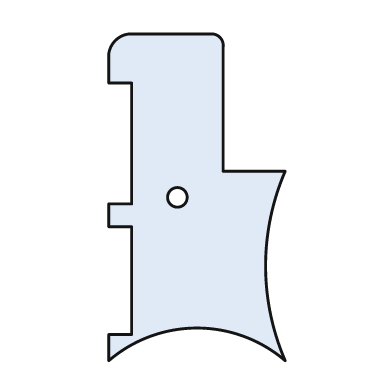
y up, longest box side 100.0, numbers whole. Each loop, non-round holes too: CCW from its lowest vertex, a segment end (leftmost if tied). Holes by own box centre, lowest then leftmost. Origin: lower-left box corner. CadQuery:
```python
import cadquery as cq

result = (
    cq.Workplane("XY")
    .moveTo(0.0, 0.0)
    .threePointArc((27.0, 10.0), (54.0, 0.0))
    .threePointArc((48.0, 29.0), (54.0, 58.0))
    .lineTo(35.0, 58.0)
    .lineTo(35.0, 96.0)
    .threePointArc((34.0, 99.0), (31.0, 100.0))
    .lineTo(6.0, 100.0)
    .threePointArc((2.0, 98.0), (0.0, 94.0))
    .lineTo(0.0, 85.0)
    .lineTo(7.0, 85.0)
    .lineTo(7.0, 48.0)
    .lineTo(0.0, 48.0)
    .lineTo(0.0, 41.0)
    .lineTo(7.0, 41.0)
    .lineTo(7.0, 8.0)
    .lineTo(0.0, 8.0)
    .close()
    .moveTo(21.0, 50.0)
    .circle(3.0)
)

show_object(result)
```